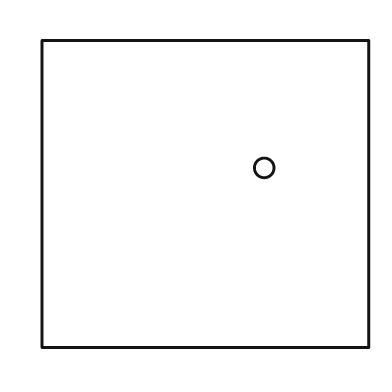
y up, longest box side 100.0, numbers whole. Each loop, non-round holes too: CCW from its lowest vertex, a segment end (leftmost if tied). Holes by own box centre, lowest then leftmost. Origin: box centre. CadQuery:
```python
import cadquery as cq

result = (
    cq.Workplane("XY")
    .moveTo(-50.0, -47.0)
    .lineTo(50.0, -47.0)
    .lineTo(50.0, 47.0)
    .lineTo(-50.0, 47.0)
    .close()
    .moveTo(18.0, 8.0)
    .circle(3.0)
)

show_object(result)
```